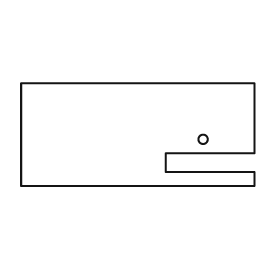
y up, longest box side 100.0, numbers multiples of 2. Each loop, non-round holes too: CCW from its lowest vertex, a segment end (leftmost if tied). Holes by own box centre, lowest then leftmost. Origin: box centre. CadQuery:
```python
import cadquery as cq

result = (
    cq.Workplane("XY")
    .moveTo(-50.0, -22.0)
    .lineTo(50.0, -22.0)
    .lineTo(50.0, -16.0)
    .lineTo(12.0, -16.0)
    .lineTo(12.0, -8.0)
    .lineTo(50.0, -8.0)
    .lineTo(50.0, 22.0)
    .lineTo(-50.0, 22.0)
    .close()
    .moveTo(28.0, -2.0)
    .circle(2.0)
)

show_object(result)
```